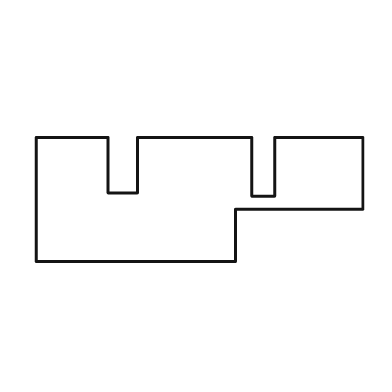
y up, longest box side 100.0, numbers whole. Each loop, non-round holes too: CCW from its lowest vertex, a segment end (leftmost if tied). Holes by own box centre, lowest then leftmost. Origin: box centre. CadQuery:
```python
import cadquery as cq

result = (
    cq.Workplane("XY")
    .moveTo(-50.0, -19.0)
    .lineTo(11.0, -19.0)
    .lineTo(11.0, -3.0)
    .lineTo(50.0, -3.0)
    .lineTo(50.0, 19.0)
    .lineTo(23.0, 19.0)
    .lineTo(23.0, 1.0)
    .lineTo(16.0, 1.0)
    .lineTo(16.0, 19.0)
    .lineTo(-19.0, 19.0)
    .lineTo(-19.0, 2.0)
    .lineTo(-28.0, 2.0)
    .lineTo(-28.0, 19.0)
    .lineTo(-50.0, 19.0)
    .close()
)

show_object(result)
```